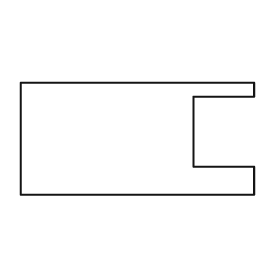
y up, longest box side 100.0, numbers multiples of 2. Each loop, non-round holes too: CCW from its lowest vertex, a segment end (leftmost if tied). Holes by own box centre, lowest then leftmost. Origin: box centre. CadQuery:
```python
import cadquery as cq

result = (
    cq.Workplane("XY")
    .moveTo(-50.0, -24.0)
    .lineTo(50.0, -24.0)
    .lineTo(50.0, -12.0)
    .lineTo(24.0, -12.0)
    .lineTo(24.0, 18.0)
    .lineTo(50.0, 18.0)
    .lineTo(50.0, 24.0)
    .lineTo(-50.0, 24.0)
    .close()
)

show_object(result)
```